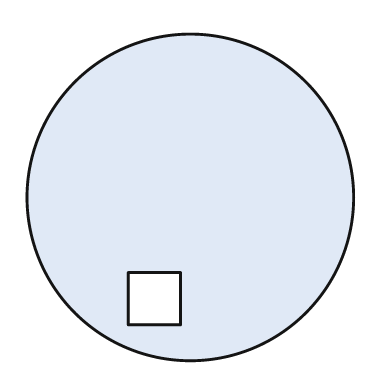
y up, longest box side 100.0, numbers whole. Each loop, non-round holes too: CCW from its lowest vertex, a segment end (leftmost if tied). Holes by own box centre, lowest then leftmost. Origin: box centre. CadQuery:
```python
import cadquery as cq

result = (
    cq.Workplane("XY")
    .moveTo(0.0, 0.0)
    .circle(50.0)
    .moveTo(-19.0, -39.0)
    .lineTo(-3.0, -39.0)
    .lineTo(-3.0, -23.0)
    .lineTo(-19.0, -23.0)
    .close()
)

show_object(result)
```